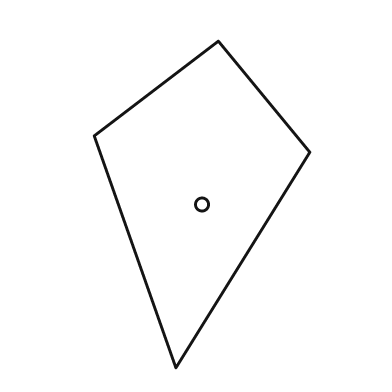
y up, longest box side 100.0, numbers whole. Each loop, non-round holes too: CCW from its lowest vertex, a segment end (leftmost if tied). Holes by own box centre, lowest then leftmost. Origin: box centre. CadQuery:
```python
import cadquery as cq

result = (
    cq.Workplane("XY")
    .moveTo(-8.0, -50.0)
    .lineTo(33.0, 16.0)
    .lineTo(5.0, 50.0)
    .lineTo(-33.0, 21.0)
    .close()
    .moveTo(0.0, 0.0)
    .circle(2.0)
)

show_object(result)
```